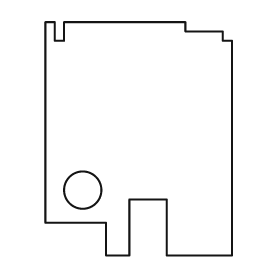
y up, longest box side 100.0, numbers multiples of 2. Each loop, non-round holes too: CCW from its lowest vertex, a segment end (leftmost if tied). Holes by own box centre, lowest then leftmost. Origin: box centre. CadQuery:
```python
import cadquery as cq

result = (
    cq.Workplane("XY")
    .moveTo(-14.0, -50.0)
    .lineTo(-4.0, -50.0)
    .lineTo(-4.0, -26.0)
    .lineTo(12.0, -26.0)
    .lineTo(12.0, -50.0)
    .lineTo(40.0, -50.0)
    .lineTo(40.0, 42.0)
    .lineTo(36.0, 42.0)
    .lineTo(36.0, 46.0)
    .lineTo(20.0, 46.0)
    .lineTo(20.0, 50.0)
    .lineTo(-32.0, 50.0)
    .lineTo(-32.0, 42.0)
    .lineTo(-36.0, 42.0)
    .lineTo(-36.0, 50.0)
    .lineTo(-40.0, 50.0)
    .lineTo(-40.0, -36.0)
    .lineTo(-14.0, -36.0)
    .close()
    .moveTo(-24.0, -22.0)
    .circle(8.0)
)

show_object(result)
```